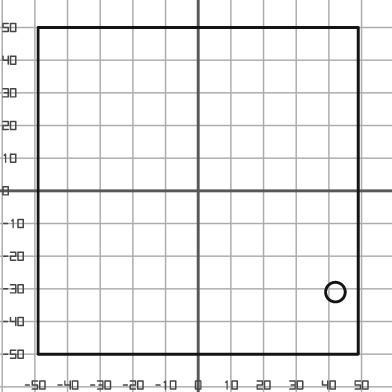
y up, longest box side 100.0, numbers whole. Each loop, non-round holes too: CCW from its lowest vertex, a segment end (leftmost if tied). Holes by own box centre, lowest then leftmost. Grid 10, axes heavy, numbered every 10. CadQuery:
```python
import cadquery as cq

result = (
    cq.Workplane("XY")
    .moveTo(-49.0, -50.0)
    .lineTo(49.0, -50.0)
    .lineTo(49.0, 50.0)
    .lineTo(-49.0, 50.0)
    .close()
    .moveTo(42.0, -31.0)
    .circle(3.0)
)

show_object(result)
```